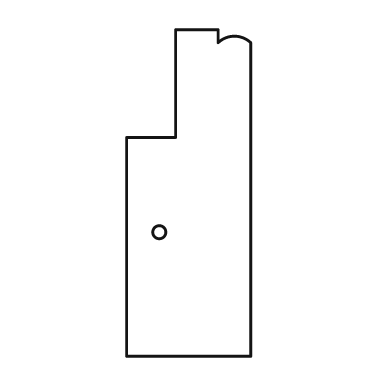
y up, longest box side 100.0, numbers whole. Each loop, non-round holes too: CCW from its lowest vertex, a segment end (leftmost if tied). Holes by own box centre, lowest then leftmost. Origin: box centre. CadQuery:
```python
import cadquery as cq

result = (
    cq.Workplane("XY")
    .moveTo(-19.0, -50.0)
    .lineTo(19.0, -50.0)
    .lineTo(19.0, 46.0)
    .threePointArc((14.0, 48.0), (9.0, 46.0))
    .lineTo(9.0, 50.0)
    .lineTo(-4.0, 50.0)
    .lineTo(-4.0, 17.0)
    .lineTo(-19.0, 17.0)
    .close()
    .moveTo(-9.0, -12.0)
    .circle(2.0)
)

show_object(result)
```